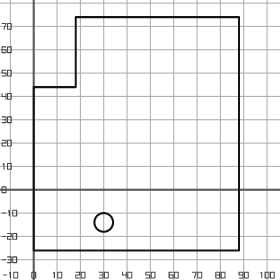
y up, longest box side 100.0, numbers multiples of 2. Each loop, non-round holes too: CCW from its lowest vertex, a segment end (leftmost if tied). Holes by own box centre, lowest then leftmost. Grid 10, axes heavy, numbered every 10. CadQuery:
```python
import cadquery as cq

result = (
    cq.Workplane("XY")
    .moveTo(0.0, -26.0)
    .lineTo(88.0, -26.0)
    .lineTo(88.0, 74.0)
    .lineTo(18.0, 74.0)
    .lineTo(18.0, 44.0)
    .lineTo(0.0, 44.0)
    .close()
    .moveTo(30.0, -14.0)
    .circle(4.0)
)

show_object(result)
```